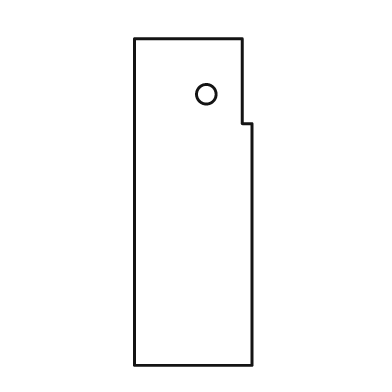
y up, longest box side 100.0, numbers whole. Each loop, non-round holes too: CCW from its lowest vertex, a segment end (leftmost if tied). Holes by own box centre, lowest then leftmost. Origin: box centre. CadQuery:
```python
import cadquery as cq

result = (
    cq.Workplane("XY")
    .moveTo(-18.0, -50.0)
    .lineTo(18.0, -50.0)
    .lineTo(18.0, 24.0)
    .lineTo(15.0, 24.0)
    .lineTo(15.0, 50.0)
    .lineTo(-18.0, 50.0)
    .close()
    .moveTo(4.0, 33.0)
    .circle(3.0)
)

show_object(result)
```